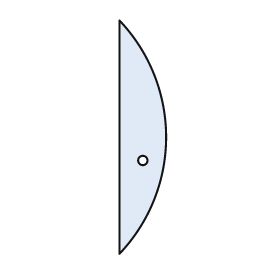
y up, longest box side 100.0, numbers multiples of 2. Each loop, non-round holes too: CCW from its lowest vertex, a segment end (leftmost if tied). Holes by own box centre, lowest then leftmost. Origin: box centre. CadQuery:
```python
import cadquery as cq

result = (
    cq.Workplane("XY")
    .moveTo(-10.0, -50.0)
    .threePointArc((10.0, 0.0), (-10.0, 50.0))
    .close()
    .moveTo(0.0, -10.0)
    .circle(2.0)
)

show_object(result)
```